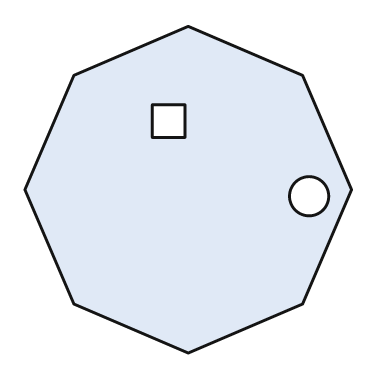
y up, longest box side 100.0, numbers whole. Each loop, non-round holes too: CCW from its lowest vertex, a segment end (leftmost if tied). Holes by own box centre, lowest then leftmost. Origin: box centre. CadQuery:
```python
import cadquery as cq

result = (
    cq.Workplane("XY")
    .moveTo(0.0, -50.0)
    .lineTo(35.0, -35.0)
    .lineTo(50.0, 0.0)
    .lineTo(35.0, 35.0)
    .lineTo(0.0, 50.0)
    .lineTo(-35.0, 35.0)
    .lineTo(-50.0, 0.0)
    .lineTo(-35.0, -35.0)
    .close()
    .moveTo(37.0, -2.0)
    .circle(6.0)
    .moveTo(-11.0, 16.0)
    .lineTo(-1.0, 16.0)
    .lineTo(-1.0, 26.0)
    .lineTo(-11.0, 26.0)
    .close()
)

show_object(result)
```